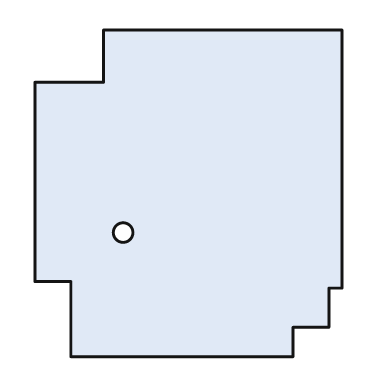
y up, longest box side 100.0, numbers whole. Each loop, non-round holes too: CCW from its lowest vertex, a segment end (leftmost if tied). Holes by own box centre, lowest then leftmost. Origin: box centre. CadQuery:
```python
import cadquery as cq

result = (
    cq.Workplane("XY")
    .moveTo(-36.0, -50.0)
    .lineTo(32.0, -50.0)
    .lineTo(32.0, -41.0)
    .lineTo(43.0, -41.0)
    .lineTo(43.0, -29.0)
    .lineTo(47.0, -29.0)
    .lineTo(47.0, 50.0)
    .lineTo(-26.0, 50.0)
    .lineTo(-26.0, 34.0)
    .lineTo(-47.0, 34.0)
    .lineTo(-47.0, -27.0)
    .lineTo(-36.0, -27.0)
    .close()
    .moveTo(-20.0, -12.0)
    .circle(3.0)
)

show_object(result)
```